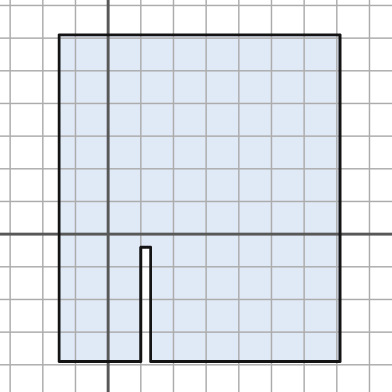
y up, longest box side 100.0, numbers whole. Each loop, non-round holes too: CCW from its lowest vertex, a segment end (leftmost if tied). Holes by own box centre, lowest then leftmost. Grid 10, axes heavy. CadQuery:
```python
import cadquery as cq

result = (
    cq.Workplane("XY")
    .moveTo(-15.0, -39.0)
    .lineTo(10.0, -39.0)
    .lineTo(10.0, -4.0)
    .lineTo(13.0, -4.0)
    .lineTo(13.0, -39.0)
    .lineTo(71.0, -39.0)
    .lineTo(71.0, 61.0)
    .lineTo(-15.0, 61.0)
    .close()
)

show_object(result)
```